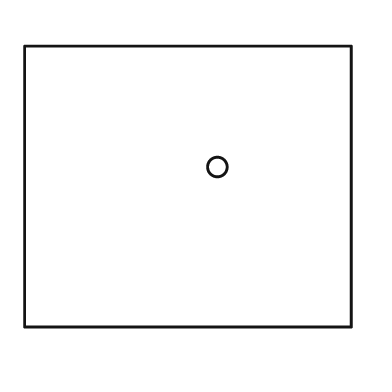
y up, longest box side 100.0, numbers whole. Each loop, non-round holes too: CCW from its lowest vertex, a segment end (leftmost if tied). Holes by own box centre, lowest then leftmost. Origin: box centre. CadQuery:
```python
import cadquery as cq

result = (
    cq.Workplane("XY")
    .moveTo(-50.0, -43.0)
    .lineTo(50.0, -43.0)
    .lineTo(50.0, 43.0)
    .lineTo(-50.0, 43.0)
    .close()
    .moveTo(9.0, 6.0)
    .circle(3.0)
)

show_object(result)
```